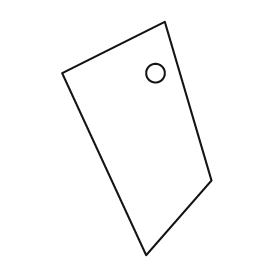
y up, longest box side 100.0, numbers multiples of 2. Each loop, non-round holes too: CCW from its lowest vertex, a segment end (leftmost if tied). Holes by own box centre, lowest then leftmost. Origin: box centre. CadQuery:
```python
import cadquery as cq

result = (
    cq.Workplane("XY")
    .moveTo(4.0, -50.0)
    .lineTo(32.0, -18.0)
    .lineTo(12.0, 50.0)
    .lineTo(-32.0, 28.0)
    .close()
    .moveTo(8.0, 28.0)
    .circle(4.0)
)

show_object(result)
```